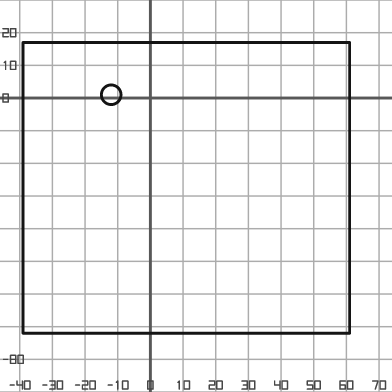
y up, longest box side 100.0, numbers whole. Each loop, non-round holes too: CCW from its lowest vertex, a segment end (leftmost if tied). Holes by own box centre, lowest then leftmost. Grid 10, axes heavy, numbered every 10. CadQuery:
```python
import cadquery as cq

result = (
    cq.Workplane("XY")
    .moveTo(-39.0, -72.0)
    .lineTo(61.0, -72.0)
    .lineTo(61.0, 17.0)
    .lineTo(-39.0, 17.0)
    .close()
    .moveTo(-12.0, 1.0)
    .circle(3.0)
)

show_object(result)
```